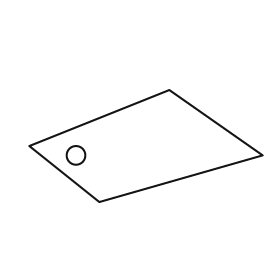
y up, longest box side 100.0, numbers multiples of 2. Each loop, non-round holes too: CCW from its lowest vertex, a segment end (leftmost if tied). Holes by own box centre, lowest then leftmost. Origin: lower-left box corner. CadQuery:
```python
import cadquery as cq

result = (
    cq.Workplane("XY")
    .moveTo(30.0, 0.0)
    .lineTo(100.0, 20.0)
    .lineTo(60.0, 48.0)
    .lineTo(0.0, 24.0)
    .close()
    .moveTo(20.0, 20.0)
    .circle(4.0)
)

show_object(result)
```